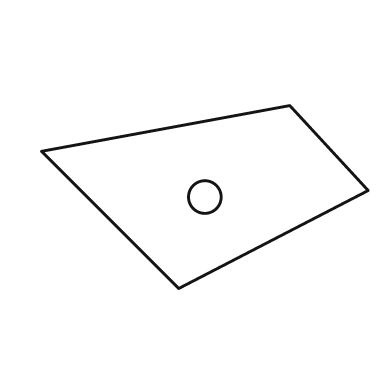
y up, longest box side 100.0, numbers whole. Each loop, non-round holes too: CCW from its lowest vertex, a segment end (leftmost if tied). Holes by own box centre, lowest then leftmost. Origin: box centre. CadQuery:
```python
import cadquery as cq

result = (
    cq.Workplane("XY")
    .moveTo(-8.0, -28.0)
    .lineTo(50.0, 2.0)
    .lineTo(26.0, 28.0)
    .lineTo(-50.0, 14.0)
    .close()
    .moveTo(0.0, 0.0)
    .circle(5.0)
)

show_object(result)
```